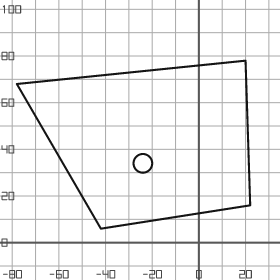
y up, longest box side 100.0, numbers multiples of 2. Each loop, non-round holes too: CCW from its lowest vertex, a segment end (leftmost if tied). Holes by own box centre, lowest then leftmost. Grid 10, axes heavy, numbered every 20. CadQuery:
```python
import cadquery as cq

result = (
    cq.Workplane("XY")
    .moveTo(-42.0, 6.0)
    .lineTo(22.0, 16.0)
    .lineTo(20.0, 78.0)
    .lineTo(-78.0, 68.0)
    .close()
    .moveTo(-24.0, 34.0)
    .circle(4.0)
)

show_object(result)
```